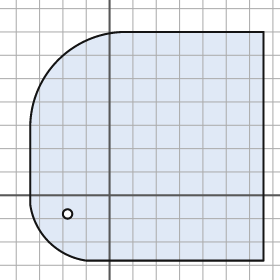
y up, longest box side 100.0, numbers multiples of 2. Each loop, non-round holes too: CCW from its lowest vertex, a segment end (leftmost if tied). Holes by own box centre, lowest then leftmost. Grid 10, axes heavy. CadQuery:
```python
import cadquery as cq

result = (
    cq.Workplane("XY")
    .moveTo(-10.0, -28.0)
    .lineTo(66.0, -28.0)
    .lineTo(66.0, 70.0)
    .lineTo(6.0, 70.0)
    .threePointArc((-22.0, 58.0), (-34.0, 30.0))
    .lineTo(-34.0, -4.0)
    .threePointArc((-26.0, -20.0), (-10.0, -28.0))
    .close()
    .moveTo(-18.0, -8.0)
    .circle(2.0)
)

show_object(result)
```